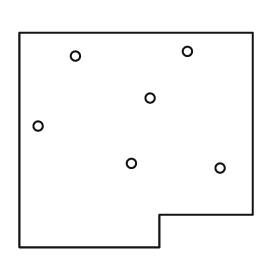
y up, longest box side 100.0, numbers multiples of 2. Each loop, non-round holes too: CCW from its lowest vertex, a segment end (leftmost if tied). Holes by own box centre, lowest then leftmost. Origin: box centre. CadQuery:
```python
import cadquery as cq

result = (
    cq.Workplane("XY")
    .moveTo(-50.0, -46.0)
    .lineTo(10.0, -46.0)
    .lineTo(10.0, -32.0)
    .lineTo(50.0, -32.0)
    .lineTo(50.0, 46.0)
    .lineTo(-50.0, 46.0)
    .close()
    .moveTo(36.0, -12.0)
    .circle(2.0)
    .moveTo(-2.0, -10.0)
    .circle(2.0)
    .moveTo(-42.0, 6.0)
    .circle(2.0)
    .moveTo(6.0, 18.0)
    .circle(2.0)
    .moveTo(-26.0, 36.0)
    .circle(2.0)
    .moveTo(22.0, 38.0)
    .circle(2.0)
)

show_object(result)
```